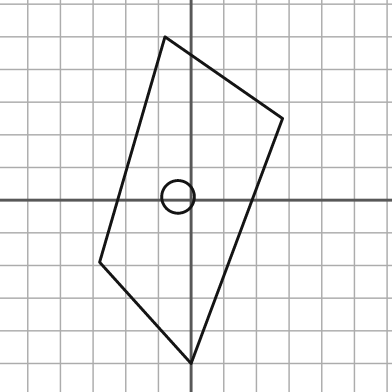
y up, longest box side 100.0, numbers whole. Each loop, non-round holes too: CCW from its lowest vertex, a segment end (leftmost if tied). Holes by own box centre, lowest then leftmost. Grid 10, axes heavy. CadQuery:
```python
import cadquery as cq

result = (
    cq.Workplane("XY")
    .moveTo(0.0, -50.0)
    .lineTo(28.0, 25.0)
    .lineTo(-8.0, 50.0)
    .lineTo(-28.0, -19.0)
    .close()
    .moveTo(-4.0, 1.0)
    .circle(5.0)
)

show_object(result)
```